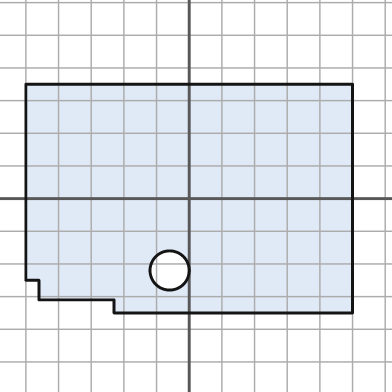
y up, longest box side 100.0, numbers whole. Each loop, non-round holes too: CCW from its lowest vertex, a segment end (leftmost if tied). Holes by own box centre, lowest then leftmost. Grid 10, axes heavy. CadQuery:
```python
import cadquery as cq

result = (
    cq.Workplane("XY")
    .moveTo(-23.0, -35.0)
    .lineTo(50.0, -35.0)
    .lineTo(50.0, 35.0)
    .lineTo(-50.0, 35.0)
    .lineTo(-50.0, -25.0)
    .lineTo(-46.0, -25.0)
    .lineTo(-46.0, -31.0)
    .lineTo(-23.0, -31.0)
    .close()
    .moveTo(-6.0, -22.0)
    .circle(6.0)
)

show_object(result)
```